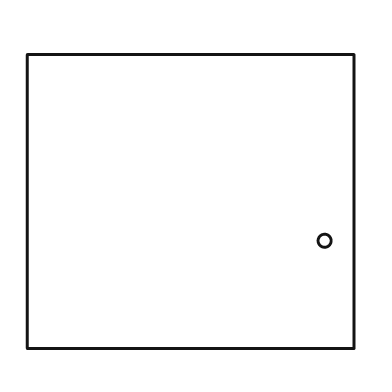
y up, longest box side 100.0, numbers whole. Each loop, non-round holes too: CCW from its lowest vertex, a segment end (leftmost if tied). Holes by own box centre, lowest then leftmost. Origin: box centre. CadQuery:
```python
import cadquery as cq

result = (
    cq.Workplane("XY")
    .moveTo(-50.0, -45.0)
    .lineTo(50.0, -45.0)
    .lineTo(50.0, 45.0)
    .lineTo(-50.0, 45.0)
    .close()
    .moveTo(41.0, -12.0)
    .circle(2.0)
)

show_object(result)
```